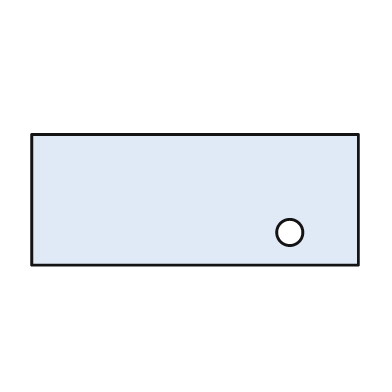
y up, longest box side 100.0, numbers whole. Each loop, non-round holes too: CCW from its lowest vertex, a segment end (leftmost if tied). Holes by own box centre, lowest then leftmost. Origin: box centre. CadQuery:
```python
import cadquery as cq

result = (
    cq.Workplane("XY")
    .moveTo(-50.0, -20.0)
    .lineTo(50.0, -20.0)
    .lineTo(50.0, 20.0)
    .lineTo(-50.0, 20.0)
    .close()
    .moveTo(29.0, -10.0)
    .circle(4.0)
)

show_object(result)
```